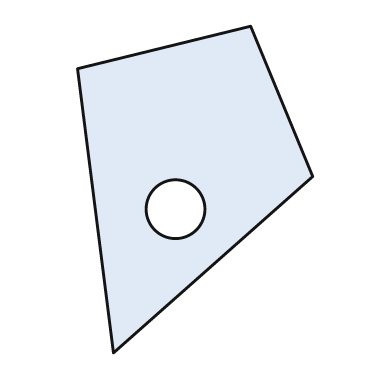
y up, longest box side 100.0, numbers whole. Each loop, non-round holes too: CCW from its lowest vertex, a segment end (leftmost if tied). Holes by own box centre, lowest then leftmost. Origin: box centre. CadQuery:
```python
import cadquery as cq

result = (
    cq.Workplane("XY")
    .moveTo(-25.0, -50.0)
    .lineTo(36.0, 4.0)
    .lineTo(17.0, 50.0)
    .lineTo(-36.0, 37.0)
    .close()
    .moveTo(-6.0, -6.0)
    .circle(9.0)
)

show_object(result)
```